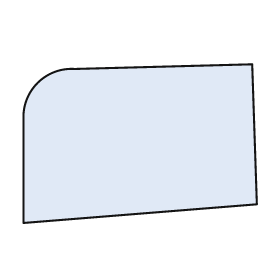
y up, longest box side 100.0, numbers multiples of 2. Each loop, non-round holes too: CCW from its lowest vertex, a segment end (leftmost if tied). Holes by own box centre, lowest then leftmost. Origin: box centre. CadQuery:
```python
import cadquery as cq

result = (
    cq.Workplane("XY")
    .moveTo(-50.0, -34.0)
    .lineTo(50.0, -26.0)
    .lineTo(48.0, 34.0)
    .lineTo(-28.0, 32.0)
    .threePointArc((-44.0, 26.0), (-50.0, 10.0))
    .close()
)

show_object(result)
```